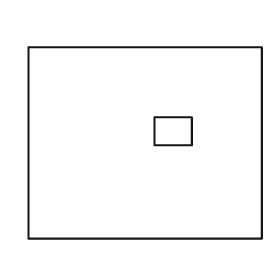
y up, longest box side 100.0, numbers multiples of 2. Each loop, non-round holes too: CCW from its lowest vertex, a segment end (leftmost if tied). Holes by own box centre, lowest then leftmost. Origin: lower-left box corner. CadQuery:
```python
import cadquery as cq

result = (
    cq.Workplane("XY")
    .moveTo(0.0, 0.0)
    .lineTo(100.0, 0.0)
    .lineTo(100.0, 82.0)
    .lineTo(0.0, 82.0)
    .close()
    .moveTo(54.0, 40.0)
    .lineTo(70.0, 40.0)
    .lineTo(70.0, 52.0)
    .lineTo(54.0, 52.0)
    .close()
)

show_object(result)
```